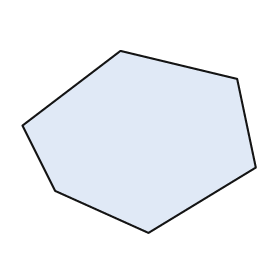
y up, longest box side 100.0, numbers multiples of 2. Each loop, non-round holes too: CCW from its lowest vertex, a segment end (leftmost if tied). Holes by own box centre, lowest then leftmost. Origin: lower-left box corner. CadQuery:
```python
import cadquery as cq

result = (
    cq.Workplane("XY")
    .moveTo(54.0, 0.0)
    .lineTo(100.0, 28.0)
    .lineTo(92.0, 66.0)
    .lineTo(42.0, 78.0)
    .lineTo(0.0, 46.0)
    .lineTo(14.0, 18.0)
    .close()
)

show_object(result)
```